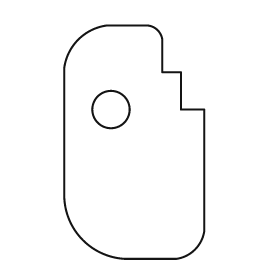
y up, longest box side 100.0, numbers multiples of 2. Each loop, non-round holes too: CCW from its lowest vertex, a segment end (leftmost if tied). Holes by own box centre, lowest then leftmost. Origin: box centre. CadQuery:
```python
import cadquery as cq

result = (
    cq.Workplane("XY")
    .moveTo(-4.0, -50.0)
    .lineTo(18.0, -50.0)
    .threePointArc((26.0, -46.0), (30.0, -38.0))
    .lineTo(30.0, 14.0)
    .lineTo(20.0, 14.0)
    .lineTo(20.0, 30.0)
    .lineTo(12.0, 30.0)
    .lineTo(12.0, 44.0)
    .threePointArc((10.0, 48.0), (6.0, 50.0))
    .lineTo(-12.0, 50.0)
    .threePointArc((-24.0, 44.0), (-30.0, 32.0))
    .lineTo(-30.0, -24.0)
    .threePointArc((-22.0, -42.0), (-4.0, -50.0))
    .close()
    .moveTo(-10.0, 14.0)
    .circle(8.0)
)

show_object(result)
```